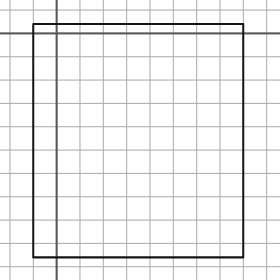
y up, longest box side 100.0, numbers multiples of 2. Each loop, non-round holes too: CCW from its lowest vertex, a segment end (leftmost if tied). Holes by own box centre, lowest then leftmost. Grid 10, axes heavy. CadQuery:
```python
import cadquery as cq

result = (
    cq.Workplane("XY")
    .moveTo(-10.0, -96.0)
    .lineTo(80.0, -96.0)
    .lineTo(80.0, 4.0)
    .lineTo(-10.0, 4.0)
    .close()
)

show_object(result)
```